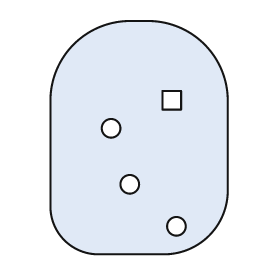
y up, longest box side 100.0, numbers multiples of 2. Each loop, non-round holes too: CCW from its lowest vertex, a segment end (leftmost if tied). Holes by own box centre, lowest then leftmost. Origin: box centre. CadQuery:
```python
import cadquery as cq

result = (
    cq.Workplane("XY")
    .moveTo(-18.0, -50.0)
    .lineTo(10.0, -50.0)
    .threePointArc((30.0, -42.0), (38.0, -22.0))
    .lineTo(38.0, 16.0)
    .threePointArc((28.0, 40.0), (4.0, 50.0))
    .lineTo(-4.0, 50.0)
    .threePointArc((-28.0, 40.0), (-38.0, 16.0))
    .lineTo(-38.0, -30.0)
    .threePointArc((-32.0, -44.0), (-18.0, -50.0))
    .close()
    .moveTo(16.0, -38.0)
    .circle(4.0)
    .moveTo(-4.0, -20.0)
    .circle(4.0)
    .moveTo(-12.0, 4.0)
    .circle(4.0)
    .moveTo(10.0, 12.0)
    .lineTo(18.0, 12.0)
    .lineTo(18.0, 20.0)
    .lineTo(10.0, 20.0)
    .close()
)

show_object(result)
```